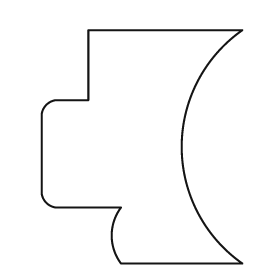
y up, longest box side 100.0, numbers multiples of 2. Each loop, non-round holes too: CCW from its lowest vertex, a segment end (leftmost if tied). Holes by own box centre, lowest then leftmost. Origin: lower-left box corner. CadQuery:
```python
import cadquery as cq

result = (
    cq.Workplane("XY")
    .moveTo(34.0, 0.0)
    .lineTo(86.0, 0.0)
    .threePointArc((60.0, 50.0), (86.0, 100.0))
    .lineTo(20.0, 100.0)
    .lineTo(20.0, 70.0)
    .lineTo(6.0, 70.0)
    .threePointArc((2.0, 68.0), (0.0, 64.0))
    .lineTo(0.0, 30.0)
    .threePointArc((2.0, 26.0), (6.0, 24.0))
    .lineTo(34.0, 24.0)
    .threePointArc((30.0, 12.0), (34.0, 0.0))
    .close()
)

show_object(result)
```